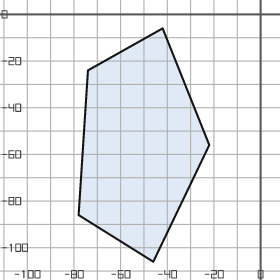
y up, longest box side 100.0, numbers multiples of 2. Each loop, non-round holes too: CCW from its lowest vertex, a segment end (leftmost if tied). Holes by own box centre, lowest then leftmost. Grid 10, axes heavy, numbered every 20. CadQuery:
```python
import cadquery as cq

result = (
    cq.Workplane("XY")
    .moveTo(-46.0, -106.0)
    .lineTo(-22.0, -56.0)
    .lineTo(-42.0, -6.0)
    .lineTo(-74.0, -24.0)
    .lineTo(-78.0, -86.0)
    .close()
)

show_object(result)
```